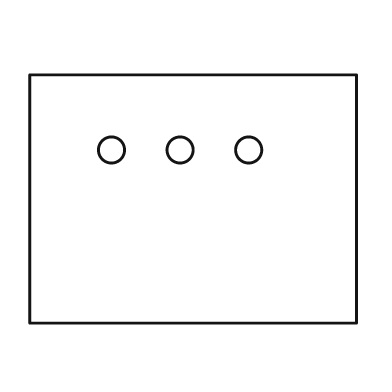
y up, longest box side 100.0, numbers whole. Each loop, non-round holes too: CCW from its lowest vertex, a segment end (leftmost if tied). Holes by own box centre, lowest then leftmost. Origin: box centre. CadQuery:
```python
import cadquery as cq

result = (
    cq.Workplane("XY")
    .moveTo(-50.0, -38.0)
    .lineTo(50.0, -38.0)
    .lineTo(50.0, 38.0)
    .lineTo(-50.0, 38.0)
    .close()
    .moveTo(-25.0, 15.0)
    .circle(4.0)
    .moveTo(-4.0, 15.0)
    .circle(4.0)
    .moveTo(17.0, 15.0)
    .circle(4.0)
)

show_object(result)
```